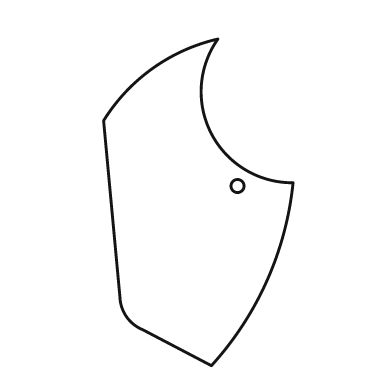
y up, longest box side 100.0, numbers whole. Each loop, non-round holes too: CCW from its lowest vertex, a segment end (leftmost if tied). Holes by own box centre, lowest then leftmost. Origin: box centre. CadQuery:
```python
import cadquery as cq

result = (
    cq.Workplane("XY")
    .moveTo(4.0, -50.0)
    .threePointArc((21.0, -24.0), (29.0, 6.0))
    .threePointArc((4.0, 21.0), (6.0, 50.0))
    .threePointArc((-14.0, 41.0), (-29.0, 25.0))
    .lineTo(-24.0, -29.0)
    .threePointArc((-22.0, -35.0), (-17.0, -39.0))
    .close()
    .moveTo(12.0, 5.0)
    .circle(2.0)
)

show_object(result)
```